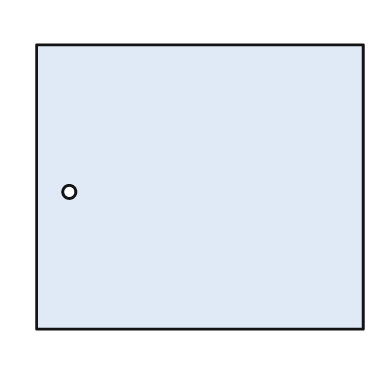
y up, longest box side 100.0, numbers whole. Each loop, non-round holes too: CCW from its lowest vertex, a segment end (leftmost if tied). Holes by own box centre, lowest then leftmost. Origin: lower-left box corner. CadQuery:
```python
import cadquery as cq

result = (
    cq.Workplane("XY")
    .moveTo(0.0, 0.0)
    .lineTo(100.0, 0.0)
    .lineTo(100.0, 87.0)
    .lineTo(0.0, 87.0)
    .close()
    .moveTo(10.0, 42.0)
    .circle(2.0)
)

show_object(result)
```